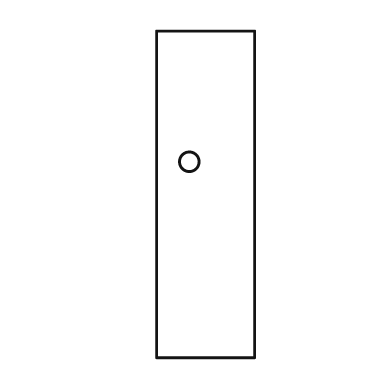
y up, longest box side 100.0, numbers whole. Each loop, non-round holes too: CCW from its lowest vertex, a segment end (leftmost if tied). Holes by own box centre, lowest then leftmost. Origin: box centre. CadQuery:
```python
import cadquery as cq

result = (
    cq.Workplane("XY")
    .moveTo(-15.0, -50.0)
    .lineTo(15.0, -50.0)
    .lineTo(15.0, 50.0)
    .lineTo(-15.0, 50.0)
    .close()
    .moveTo(-5.0, 10.0)
    .circle(3.0)
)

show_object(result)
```